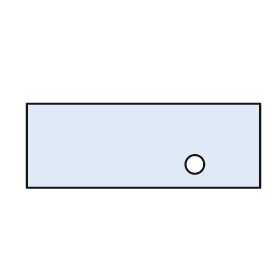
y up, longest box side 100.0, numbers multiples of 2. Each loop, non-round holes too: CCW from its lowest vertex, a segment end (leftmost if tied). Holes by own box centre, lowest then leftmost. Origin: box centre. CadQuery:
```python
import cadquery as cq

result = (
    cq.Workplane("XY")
    .moveTo(-50.0, -18.0)
    .lineTo(50.0, -18.0)
    .lineTo(50.0, 18.0)
    .lineTo(-50.0, 18.0)
    .close()
    .moveTo(22.0, -8.0)
    .circle(4.0)
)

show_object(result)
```